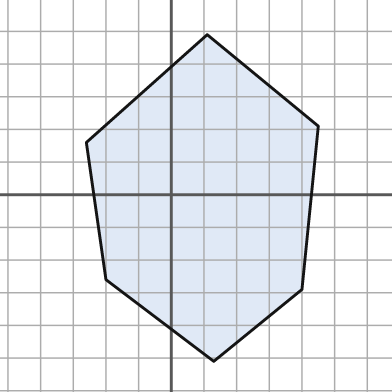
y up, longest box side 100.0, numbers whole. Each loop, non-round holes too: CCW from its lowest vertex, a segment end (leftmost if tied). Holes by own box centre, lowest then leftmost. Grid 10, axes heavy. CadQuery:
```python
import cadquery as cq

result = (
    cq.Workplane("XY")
    .moveTo(13.0, -51.0)
    .lineTo(40.0, -29.0)
    .lineTo(45.0, 21.0)
    .lineTo(11.0, 49.0)
    .lineTo(-26.0, 16.0)
    .lineTo(-20.0, -26.0)
    .close()
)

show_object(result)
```